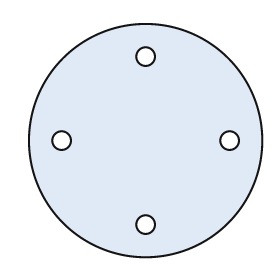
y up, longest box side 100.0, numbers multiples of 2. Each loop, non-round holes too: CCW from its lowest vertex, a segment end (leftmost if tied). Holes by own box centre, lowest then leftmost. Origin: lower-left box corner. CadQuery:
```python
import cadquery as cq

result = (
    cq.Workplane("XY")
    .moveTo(50.0, 50.0)
    .circle(50.0)
    .moveTo(50.0, 14.0)
    .circle(4.0)
    .moveTo(14.0, 50.0)
    .circle(4.0)
    .moveTo(86.0, 50.0)
    .circle(4.0)
    .moveTo(50.0, 86.0)
    .circle(4.0)
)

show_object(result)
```